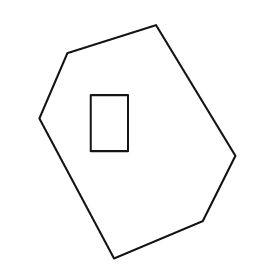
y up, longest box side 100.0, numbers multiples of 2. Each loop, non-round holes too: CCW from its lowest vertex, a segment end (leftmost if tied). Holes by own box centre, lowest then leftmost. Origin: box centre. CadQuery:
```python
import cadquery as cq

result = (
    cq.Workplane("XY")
    .moveTo(-10.0, -50.0)
    .lineTo(28.0, -34.0)
    .lineTo(42.0, -6.0)
    .lineTo(8.0, 50.0)
    .lineTo(-30.0, 38.0)
    .lineTo(-42.0, 10.0)
    .close()
    .moveTo(-20.0, -4.0)
    .lineTo(-4.0, -4.0)
    .lineTo(-4.0, 20.0)
    .lineTo(-20.0, 20.0)
    .close()
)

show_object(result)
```